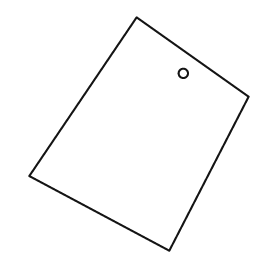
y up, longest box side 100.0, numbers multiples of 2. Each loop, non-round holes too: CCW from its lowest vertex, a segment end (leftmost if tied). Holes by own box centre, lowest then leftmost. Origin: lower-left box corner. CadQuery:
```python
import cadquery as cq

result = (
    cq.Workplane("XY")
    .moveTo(60.0, 0.0)
    .lineTo(94.0, 66.0)
    .lineTo(46.0, 100.0)
    .lineTo(0.0, 32.0)
    .close()
    .moveTo(66.0, 76.0)
    .circle(2.0)
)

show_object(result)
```